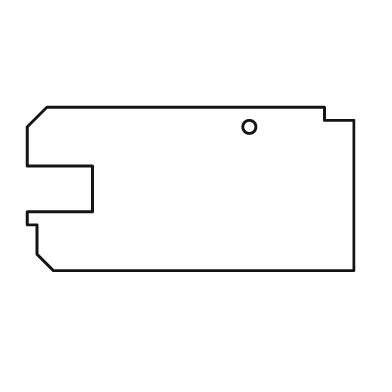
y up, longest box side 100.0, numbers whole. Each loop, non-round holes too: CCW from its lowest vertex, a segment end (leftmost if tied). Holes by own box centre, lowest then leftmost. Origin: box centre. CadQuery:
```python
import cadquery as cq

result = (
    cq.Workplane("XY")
    .moveTo(-42.0, -25.0)
    .lineTo(50.0, -25.0)
    .lineTo(50.0, 21.0)
    .lineTo(41.0, 21.0)
    .lineTo(41.0, 25.0)
    .lineTo(-44.0, 25.0)
    .lineTo(-50.0, 19.0)
    .lineTo(-50.0, 7.0)
    .lineTo(-30.0, 7.0)
    .lineTo(-30.0, -7.0)
    .lineTo(-50.0, -7.0)
    .lineTo(-50.0, -11.0)
    .lineTo(-47.0, -11.0)
    .lineTo(-47.0, -20.0)
    .close()
    .moveTo(18.0, 19.0)
    .circle(2.0)
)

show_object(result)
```